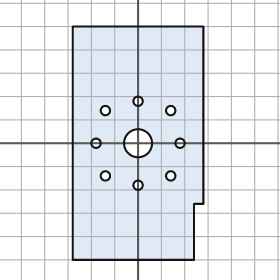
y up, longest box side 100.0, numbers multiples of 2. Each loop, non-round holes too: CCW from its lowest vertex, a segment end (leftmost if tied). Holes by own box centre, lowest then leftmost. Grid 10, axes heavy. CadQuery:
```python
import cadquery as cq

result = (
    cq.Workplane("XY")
    .moveTo(-28.0, -50.0)
    .lineTo(24.0, -50.0)
    .lineTo(24.0, -26.0)
    .lineTo(28.0, -26.0)
    .lineTo(28.0, 50.0)
    .lineTo(-28.0, 50.0)
    .close()
    .moveTo(0.0, -18.0)
    .circle(2.0)
    .moveTo(-14.0, -14.0)
    .circle(2.0)
    .moveTo(14.0, -14.0)
    .circle(2.0)
    .moveTo(-18.0, 0.0)
    .circle(2.0)
    .moveTo(0.0, 0.0)
    .circle(6.0)
    .moveTo(18.0, 0.0)
    .circle(2.0)
    .moveTo(-14.0, 14.0)
    .circle(2.0)
    .moveTo(14.0, 14.0)
    .circle(2.0)
    .moveTo(0.0, 18.0)
    .circle(2.0)
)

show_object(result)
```